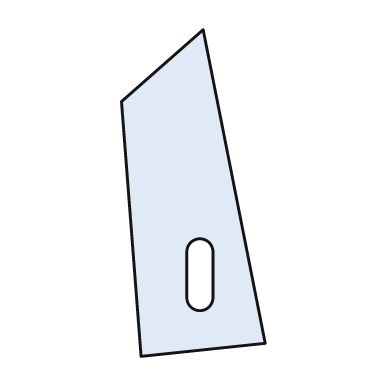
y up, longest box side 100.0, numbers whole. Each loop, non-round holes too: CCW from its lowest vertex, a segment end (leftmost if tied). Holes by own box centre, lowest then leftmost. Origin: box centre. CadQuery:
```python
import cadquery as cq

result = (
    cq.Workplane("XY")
    .moveTo(-16.0, -50.0)
    .lineTo(22.0, -46.0)
    .lineTo(3.0, 50.0)
    .lineTo(-22.0, 28.0)
    .close()
    .moveTo(-2.0, -32.0)
    .threePointArc((2.0, -36.0), (6.0, -32.0))
    .lineTo(6.0, -18.0)
    .threePointArc((2.0, -14.0), (-2.0, -18.0))
    .close()
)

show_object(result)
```